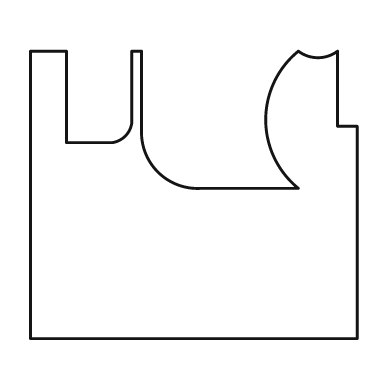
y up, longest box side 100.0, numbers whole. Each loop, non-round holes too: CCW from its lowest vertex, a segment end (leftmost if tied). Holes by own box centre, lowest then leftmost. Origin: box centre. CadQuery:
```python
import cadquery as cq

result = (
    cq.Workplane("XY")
    .moveTo(-50.0, -44.0)
    .lineTo(50.0, -44.0)
    .lineTo(50.0, 21.0)
    .lineTo(44.0, 21.0)
    .lineTo(44.0, 44.0)
    .threePointArc((38.0, 42.0), (32.0, 44.0))
    .threePointArc((22.0, 23.0), (32.0, 2.0))
    .lineTo(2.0, 2.0)
    .threePointArc((-11.0, 7.0), (-16.0, 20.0))
    .lineTo(-16.0, 44.0)
    .lineTo(-19.0, 44.0)
    .lineTo(-19.0, 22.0)
    .threePointArc((-21.0, 18.0), (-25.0, 16.0))
    .lineTo(-39.0, 16.0)
    .lineTo(-39.0, 44.0)
    .lineTo(-50.0, 44.0)
    .close()
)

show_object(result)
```